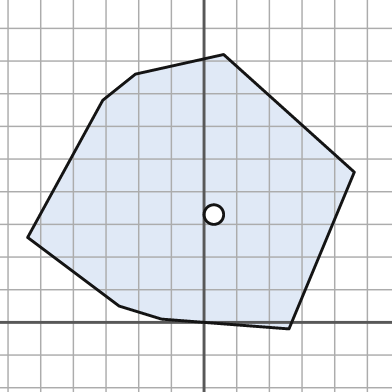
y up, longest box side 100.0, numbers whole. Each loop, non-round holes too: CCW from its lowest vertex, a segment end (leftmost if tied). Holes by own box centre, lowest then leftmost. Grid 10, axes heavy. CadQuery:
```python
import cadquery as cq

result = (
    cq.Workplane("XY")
    .moveTo(26.0, -2.0)
    .lineTo(46.0, 46.0)
    .lineTo(6.0, 82.0)
    .lineTo(-21.0, 76.0)
    .lineTo(-31.0, 68.0)
    .lineTo(-54.0, 26.0)
    .lineTo(-26.0, 5.0)
    .lineTo(-13.0, 1.0)
    .close()
    .moveTo(3.0, 33.0)
    .circle(3.0)
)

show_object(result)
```